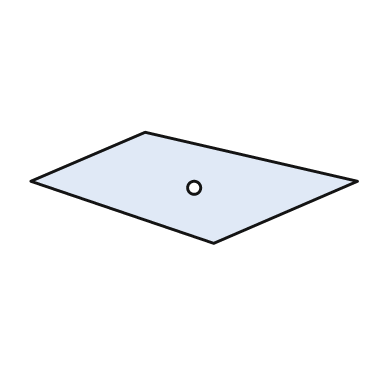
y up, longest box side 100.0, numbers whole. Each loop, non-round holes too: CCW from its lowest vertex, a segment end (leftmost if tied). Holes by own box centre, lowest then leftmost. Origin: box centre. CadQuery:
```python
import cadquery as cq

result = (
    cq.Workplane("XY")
    .moveTo(6.0, -17.0)
    .lineTo(50.0, 2.0)
    .lineTo(-15.0, 17.0)
    .lineTo(-50.0, 2.0)
    .close()
    .moveTo(0.0, 0.0)
    .circle(2.0)
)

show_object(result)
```